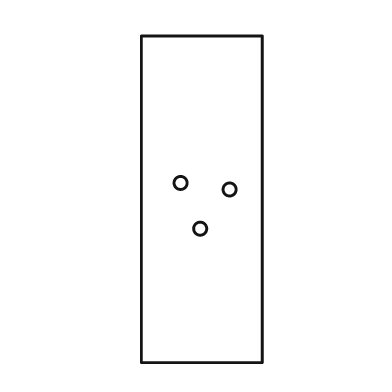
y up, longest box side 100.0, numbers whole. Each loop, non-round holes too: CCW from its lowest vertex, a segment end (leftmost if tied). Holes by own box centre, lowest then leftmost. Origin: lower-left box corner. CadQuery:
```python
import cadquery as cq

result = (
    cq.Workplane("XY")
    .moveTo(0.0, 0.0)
    .lineTo(37.0, 0.0)
    .lineTo(37.0, 100.0)
    .lineTo(0.0, 100.0)
    .close()
    .moveTo(18.0, 41.0)
    .circle(2.0)
    .moveTo(27.0, 53.0)
    .circle(2.0)
    .moveTo(12.0, 55.0)
    .circle(2.0)
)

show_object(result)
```